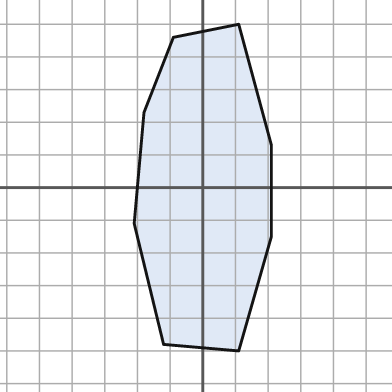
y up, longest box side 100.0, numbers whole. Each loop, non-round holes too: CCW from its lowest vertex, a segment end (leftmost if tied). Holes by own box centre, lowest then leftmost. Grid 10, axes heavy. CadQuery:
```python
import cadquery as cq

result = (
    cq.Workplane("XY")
    .moveTo(11.0, -50.0)
    .lineTo(21.0, -15.0)
    .lineTo(21.0, 13.0)
    .lineTo(11.0, 50.0)
    .lineTo(-9.0, 46.0)
    .lineTo(-18.0, 23.0)
    .lineTo(-21.0, -11.0)
    .lineTo(-12.0, -48.0)
    .close()
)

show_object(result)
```